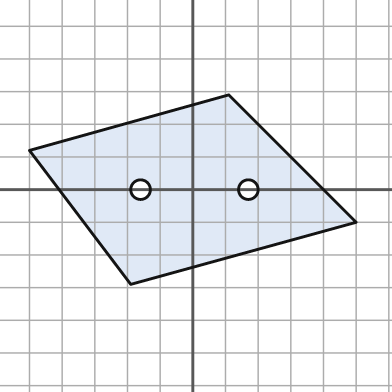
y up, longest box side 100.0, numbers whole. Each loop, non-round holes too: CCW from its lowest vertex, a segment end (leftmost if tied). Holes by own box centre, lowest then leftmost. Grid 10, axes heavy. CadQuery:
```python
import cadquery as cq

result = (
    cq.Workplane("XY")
    .moveTo(-19.0, -29.0)
    .lineTo(50.0, -10.0)
    .lineTo(11.0, 29.0)
    .lineTo(-50.0, 12.0)
    .close()
    .moveTo(-16.0, 0.0)
    .circle(3.0)
    .moveTo(17.0, 0.0)
    .circle(3.0)
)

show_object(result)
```